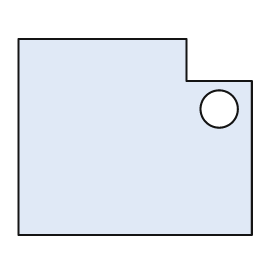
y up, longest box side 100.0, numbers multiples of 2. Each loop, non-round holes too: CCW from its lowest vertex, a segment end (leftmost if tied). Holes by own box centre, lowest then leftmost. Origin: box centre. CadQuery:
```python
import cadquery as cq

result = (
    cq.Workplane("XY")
    .moveTo(-50.0, -42.0)
    .lineTo(50.0, -42.0)
    .lineTo(50.0, 24.0)
    .lineTo(22.0, 24.0)
    .lineTo(22.0, 42.0)
    .lineTo(-50.0, 42.0)
    .close()
    .moveTo(36.0, 12.0)
    .circle(8.0)
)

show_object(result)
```